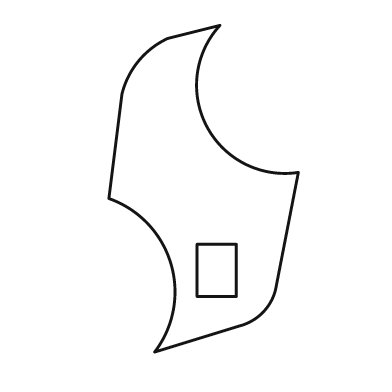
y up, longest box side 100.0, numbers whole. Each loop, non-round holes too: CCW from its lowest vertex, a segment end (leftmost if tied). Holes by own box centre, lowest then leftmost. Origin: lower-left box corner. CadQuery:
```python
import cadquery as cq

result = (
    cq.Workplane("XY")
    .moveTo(14.0, 0.0)
    .lineTo(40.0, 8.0)
    .threePointArc((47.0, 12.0), (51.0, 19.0))
    .lineTo(58.0, 55.0)
    .threePointArc((30.0, 69.0), (34.0, 100.0))
    .lineTo(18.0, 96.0)
    .threePointArc((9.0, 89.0), (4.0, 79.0))
    .lineTo(0.0, 47.0)
    .threePointArc((19.0, 27.0), (14.0, 0.0))
    .close()
    .moveTo(27.0, 17.0)
    .lineTo(39.0, 17.0)
    .lineTo(39.0, 33.0)
    .lineTo(27.0, 33.0)
    .close()
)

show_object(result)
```